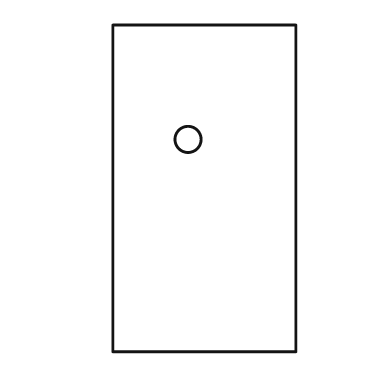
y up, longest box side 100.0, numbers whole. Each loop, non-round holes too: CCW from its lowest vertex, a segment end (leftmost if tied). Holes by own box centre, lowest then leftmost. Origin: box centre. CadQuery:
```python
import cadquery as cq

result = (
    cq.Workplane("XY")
    .moveTo(-28.0, -50.0)
    .lineTo(28.0, -50.0)
    .lineTo(28.0, 50.0)
    .lineTo(-28.0, 50.0)
    .close()
    .moveTo(-5.0, 15.0)
    .circle(4.0)
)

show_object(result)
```